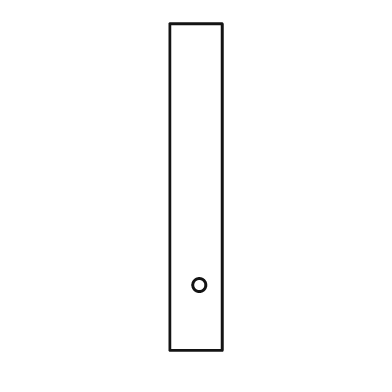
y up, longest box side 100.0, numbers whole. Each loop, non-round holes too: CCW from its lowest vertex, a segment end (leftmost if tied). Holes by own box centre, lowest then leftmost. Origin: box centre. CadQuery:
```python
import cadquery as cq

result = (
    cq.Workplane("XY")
    .moveTo(-8.0, -50.0)
    .lineTo(8.0, -50.0)
    .lineTo(8.0, 50.0)
    .lineTo(-8.0, 50.0)
    .close()
    .moveTo(1.0, -30.0)
    .circle(2.0)
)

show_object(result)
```